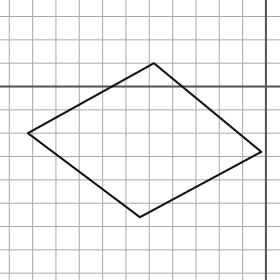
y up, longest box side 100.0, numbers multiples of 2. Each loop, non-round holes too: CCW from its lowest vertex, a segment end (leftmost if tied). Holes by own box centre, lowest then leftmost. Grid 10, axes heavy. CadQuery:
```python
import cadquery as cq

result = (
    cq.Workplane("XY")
    .moveTo(-54.0, -56.0)
    .lineTo(-2.0, -28.0)
    .lineTo(-48.0, 10.0)
    .lineTo(-102.0, -20.0)
    .close()
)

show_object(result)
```